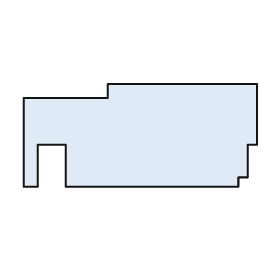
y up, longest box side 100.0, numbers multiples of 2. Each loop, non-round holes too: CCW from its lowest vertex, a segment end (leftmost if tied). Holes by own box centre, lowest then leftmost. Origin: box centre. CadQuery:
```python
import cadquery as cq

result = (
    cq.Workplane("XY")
    .moveTo(-50.0, -22.0)
    .lineTo(-44.0, -22.0)
    .lineTo(-44.0, -4.0)
    .lineTo(-32.0, -4.0)
    .lineTo(-32.0, -22.0)
    .lineTo(42.0, -22.0)
    .lineTo(42.0, -18.0)
    .lineTo(46.0, -18.0)
    .lineTo(46.0, -4.0)
    .lineTo(50.0, -4.0)
    .lineTo(50.0, 22.0)
    .lineTo(-14.0, 22.0)
    .lineTo(-14.0, 16.0)
    .lineTo(-50.0, 16.0)
    .close()
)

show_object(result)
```